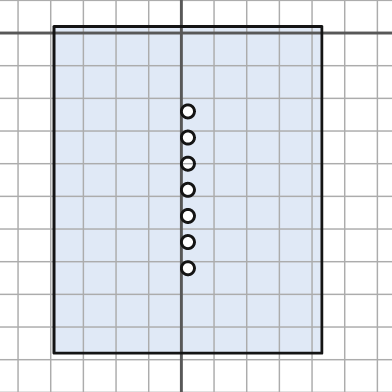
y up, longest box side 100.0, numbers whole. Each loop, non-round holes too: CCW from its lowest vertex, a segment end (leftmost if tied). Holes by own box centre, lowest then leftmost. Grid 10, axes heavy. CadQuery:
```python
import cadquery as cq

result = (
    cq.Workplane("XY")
    .moveTo(-39.0, -98.0)
    .lineTo(43.0, -98.0)
    .lineTo(43.0, 2.0)
    .lineTo(-39.0, 2.0)
    .close()
    .moveTo(2.0, -72.0)
    .circle(2.0)
    .moveTo(2.0, -64.0)
    .circle(2.0)
    .moveTo(2.0, -56.0)
    .circle(2.0)
    .moveTo(2.0, -48.0)
    .circle(2.0)
    .moveTo(2.0, -40.0)
    .circle(2.0)
    .moveTo(2.0, -32.0)
    .circle(2.0)
    .moveTo(2.0, -24.0)
    .circle(2.0)
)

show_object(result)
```